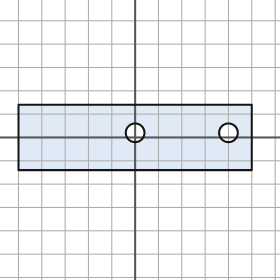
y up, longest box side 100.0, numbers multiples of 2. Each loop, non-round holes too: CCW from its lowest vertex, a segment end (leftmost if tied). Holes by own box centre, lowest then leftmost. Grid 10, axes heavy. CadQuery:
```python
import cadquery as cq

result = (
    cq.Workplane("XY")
    .moveTo(-50.0, -14.0)
    .lineTo(50.0, -14.0)
    .lineTo(50.0, 14.0)
    .lineTo(-50.0, 14.0)
    .close()
    .moveTo(0.0, 2.0)
    .circle(4.0)
    .moveTo(40.0, 2.0)
    .circle(4.0)
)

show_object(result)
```